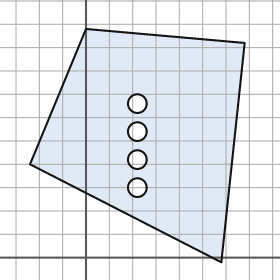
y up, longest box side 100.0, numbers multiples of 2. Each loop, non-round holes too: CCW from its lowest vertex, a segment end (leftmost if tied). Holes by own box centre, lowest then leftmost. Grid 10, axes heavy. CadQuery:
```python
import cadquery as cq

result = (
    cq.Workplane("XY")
    .moveTo(58.0, -2.0)
    .lineTo(68.0, 92.0)
    .lineTo(0.0, 98.0)
    .lineTo(-24.0, 40.0)
    .close()
    .moveTo(22.0, 30.0)
    .circle(4.0)
    .moveTo(22.0, 42.0)
    .circle(4.0)
    .moveTo(22.0, 54.0)
    .circle(4.0)
    .moveTo(22.0, 66.0)
    .circle(4.0)
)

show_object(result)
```